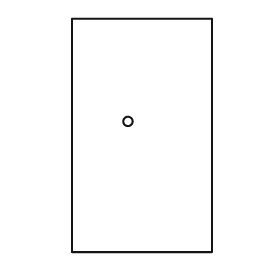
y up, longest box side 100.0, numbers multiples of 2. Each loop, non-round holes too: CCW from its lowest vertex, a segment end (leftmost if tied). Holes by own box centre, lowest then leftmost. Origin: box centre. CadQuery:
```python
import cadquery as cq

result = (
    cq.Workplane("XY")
    .moveTo(-30.0, -50.0)
    .lineTo(30.0, -50.0)
    .lineTo(30.0, 50.0)
    .lineTo(-30.0, 50.0)
    .close()
    .moveTo(-6.0, 6.0)
    .circle(2.0)
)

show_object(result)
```